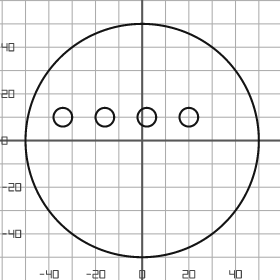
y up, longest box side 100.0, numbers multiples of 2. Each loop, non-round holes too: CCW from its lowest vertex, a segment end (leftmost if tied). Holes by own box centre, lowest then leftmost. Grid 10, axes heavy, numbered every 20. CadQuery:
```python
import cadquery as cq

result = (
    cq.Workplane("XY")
    .moveTo(0.0, 0.0)
    .circle(50.0)
    .moveTo(-34.0, 10.0)
    .circle(4.0)
    .moveTo(-16.0, 10.0)
    .circle(4.0)
    .moveTo(2.0, 10.0)
    .circle(4.0)
    .moveTo(20.0, 10.0)
    .circle(4.0)
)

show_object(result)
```